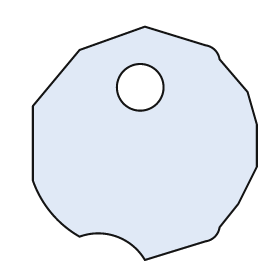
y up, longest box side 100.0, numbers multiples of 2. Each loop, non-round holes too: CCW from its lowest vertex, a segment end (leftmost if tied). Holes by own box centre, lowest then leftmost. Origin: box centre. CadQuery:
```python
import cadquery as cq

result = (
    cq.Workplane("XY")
    .moveTo(0.0, -50.0)
    .lineTo(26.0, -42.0)
    .threePointArc((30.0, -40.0), (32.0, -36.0))
    .lineTo(40.0, -26.0)
    .lineTo(48.0, -10.0)
    .lineTo(48.0, 8.0)
    .lineTo(44.0, 22.0)
    .lineTo(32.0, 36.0)
    .threePointArc((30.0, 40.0), (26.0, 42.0))
    .lineTo(0.0, 50.0)
    .lineTo(-28.0, 40.0)
    .lineTo(-48.0, 16.0)
    .lineTo(-48.0, -16.0)
    .threePointArc((-40.0, -30.0), (-28.0, -40.0))
    .threePointArc((-12.0, -40.0), (0.0, -50.0))
    .close()
    .moveTo(-2.0, 24.0)
    .circle(10.0)
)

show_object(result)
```